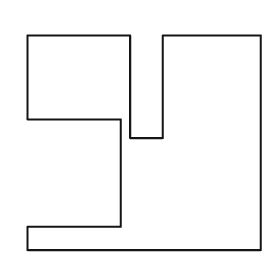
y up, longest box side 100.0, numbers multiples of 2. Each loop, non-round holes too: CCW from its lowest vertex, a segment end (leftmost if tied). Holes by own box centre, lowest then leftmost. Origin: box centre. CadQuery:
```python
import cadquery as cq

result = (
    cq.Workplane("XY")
    .moveTo(-50.0, -46.0)
    .lineTo(50.0, -46.0)
    .lineTo(50.0, 46.0)
    .lineTo(8.0, 46.0)
    .lineTo(8.0, 2.0)
    .lineTo(-6.0, 2.0)
    .lineTo(-6.0, 46.0)
    .lineTo(-50.0, 46.0)
    .lineTo(-50.0, 10.0)
    .lineTo(-10.0, 10.0)
    .lineTo(-10.0, -36.0)
    .lineTo(-50.0, -36.0)
    .close()
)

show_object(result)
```